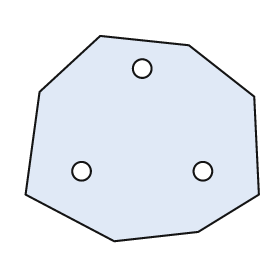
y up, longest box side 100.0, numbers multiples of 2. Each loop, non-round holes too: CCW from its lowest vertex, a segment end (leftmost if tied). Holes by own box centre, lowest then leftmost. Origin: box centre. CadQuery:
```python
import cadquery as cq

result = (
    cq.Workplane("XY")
    .moveTo(-12.0, -44.0)
    .lineTo(24.0, -40.0)
    .lineTo(50.0, -24.0)
    .lineTo(48.0, 18.0)
    .lineTo(20.0, 40.0)
    .lineTo(-18.0, 44.0)
    .lineTo(-44.0, 20.0)
    .lineTo(-50.0, -24.0)
    .close()
    .moveTo(-26.0, -14.0)
    .circle(4.0)
    .moveTo(26.0, -14.0)
    .circle(4.0)
    .moveTo(0.0, 30.0)
    .circle(4.0)
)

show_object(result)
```